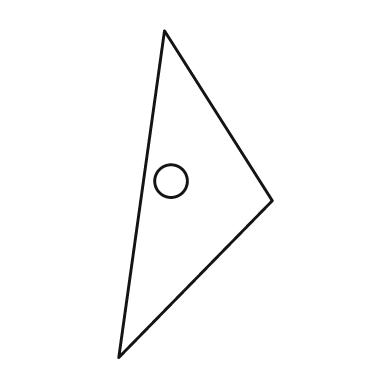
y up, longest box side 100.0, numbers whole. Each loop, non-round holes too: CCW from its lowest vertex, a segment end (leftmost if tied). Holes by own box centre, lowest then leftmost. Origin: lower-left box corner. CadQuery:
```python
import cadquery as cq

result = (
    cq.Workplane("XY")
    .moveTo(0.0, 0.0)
    .lineTo(47.0, 48.0)
    .lineTo(14.0, 100.0)
    .close()
    .moveTo(16.0, 54.0)
    .circle(5.0)
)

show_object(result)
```